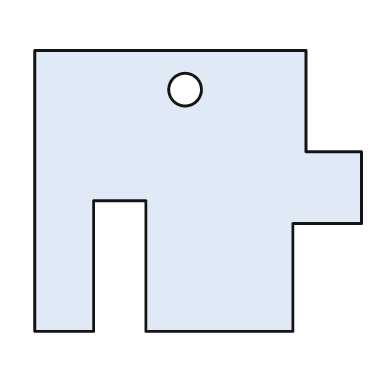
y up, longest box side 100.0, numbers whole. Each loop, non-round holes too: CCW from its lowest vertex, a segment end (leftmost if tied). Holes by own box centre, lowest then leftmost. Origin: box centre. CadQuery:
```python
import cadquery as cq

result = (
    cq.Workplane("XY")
    .moveTo(-50.0, -43.0)
    .lineTo(-32.0, -43.0)
    .lineTo(-32.0, -3.0)
    .lineTo(-16.0, -3.0)
    .lineTo(-16.0, -43.0)
    .lineTo(29.0, -43.0)
    .lineTo(29.0, -10.0)
    .lineTo(50.0, -10.0)
    .lineTo(50.0, 12.0)
    .lineTo(33.0, 12.0)
    .lineTo(33.0, 43.0)
    .lineTo(-50.0, 43.0)
    .close()
    .moveTo(-4.0, 31.0)
    .circle(5.0)
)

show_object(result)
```